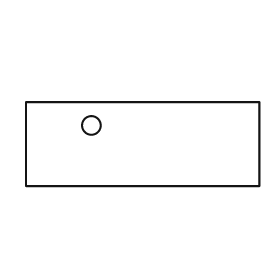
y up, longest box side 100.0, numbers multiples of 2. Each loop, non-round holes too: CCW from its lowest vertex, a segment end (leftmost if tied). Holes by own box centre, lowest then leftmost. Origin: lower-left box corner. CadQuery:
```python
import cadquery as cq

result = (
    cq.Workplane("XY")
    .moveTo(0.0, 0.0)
    .lineTo(100.0, 0.0)
    .lineTo(100.0, 36.0)
    .lineTo(0.0, 36.0)
    .close()
    .moveTo(28.0, 26.0)
    .circle(4.0)
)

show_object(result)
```